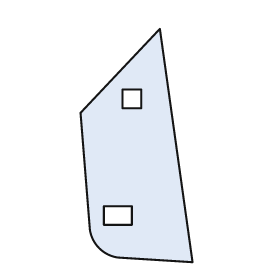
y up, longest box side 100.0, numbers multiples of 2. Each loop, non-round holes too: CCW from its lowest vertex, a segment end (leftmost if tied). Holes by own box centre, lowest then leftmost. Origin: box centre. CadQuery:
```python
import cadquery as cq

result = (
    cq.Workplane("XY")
    .moveTo(24.0, -50.0)
    .lineTo(10.0, 50.0)
    .lineTo(-24.0, 14.0)
    .lineTo(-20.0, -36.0)
    .threePointArc((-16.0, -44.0), (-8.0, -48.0))
    .close()
    .moveTo(-14.0, -34.0)
    .lineTo(-2.0, -34.0)
    .lineTo(-2.0, -26.0)
    .lineTo(-14.0, -26.0)
    .close()
    .moveTo(-6.0, 16.0)
    .lineTo(2.0, 16.0)
    .lineTo(2.0, 24.0)
    .lineTo(-6.0, 24.0)
    .close()
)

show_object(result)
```